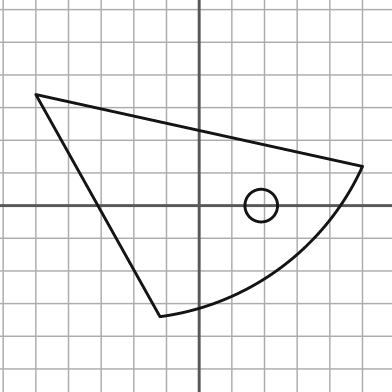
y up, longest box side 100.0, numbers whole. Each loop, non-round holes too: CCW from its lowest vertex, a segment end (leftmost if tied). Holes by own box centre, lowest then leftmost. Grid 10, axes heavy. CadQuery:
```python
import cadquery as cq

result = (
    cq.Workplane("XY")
    .moveTo(-12.0, -34.0)
    .threePointArc((25.0, -19.0), (50.0, 12.0))
    .lineTo(-50.0, 34.0)
    .close()
    .moveTo(19.0, 0.0)
    .circle(5.0)
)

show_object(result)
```